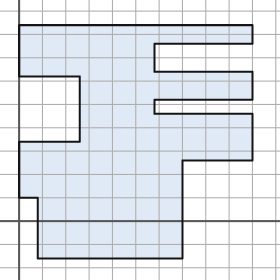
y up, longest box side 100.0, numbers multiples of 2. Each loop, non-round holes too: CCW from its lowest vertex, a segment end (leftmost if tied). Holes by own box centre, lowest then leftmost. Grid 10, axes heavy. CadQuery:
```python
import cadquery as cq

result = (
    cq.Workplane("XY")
    .moveTo(8.0, -16.0)
    .lineTo(70.0, -16.0)
    .lineTo(70.0, 26.0)
    .lineTo(100.0, 26.0)
    .lineTo(100.0, 46.0)
    .lineTo(58.0, 46.0)
    .lineTo(58.0, 52.0)
    .lineTo(100.0, 52.0)
    .lineTo(100.0, 64.0)
    .lineTo(58.0, 64.0)
    .lineTo(58.0, 76.0)
    .lineTo(100.0, 76.0)
    .lineTo(100.0, 84.0)
    .lineTo(0.0, 84.0)
    .lineTo(0.0, 62.0)
    .lineTo(26.0, 62.0)
    .lineTo(26.0, 34.0)
    .lineTo(0.0, 34.0)
    .lineTo(0.0, 10.0)
    .lineTo(8.0, 10.0)
    .close()
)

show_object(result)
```